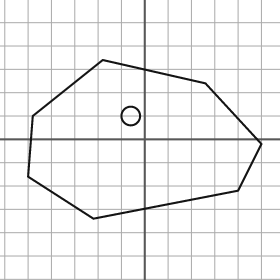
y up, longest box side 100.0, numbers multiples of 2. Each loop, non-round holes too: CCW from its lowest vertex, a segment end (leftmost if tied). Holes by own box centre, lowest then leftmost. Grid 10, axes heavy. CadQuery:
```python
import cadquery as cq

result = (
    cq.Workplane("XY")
    .moveTo(-22.0, -34.0)
    .lineTo(40.0, -22.0)
    .lineTo(50.0, -2.0)
    .lineTo(26.0, 24.0)
    .lineTo(-18.0, 34.0)
    .lineTo(-48.0, 10.0)
    .lineTo(-50.0, -16.0)
    .close()
    .moveTo(-6.0, 10.0)
    .circle(4.0)
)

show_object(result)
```